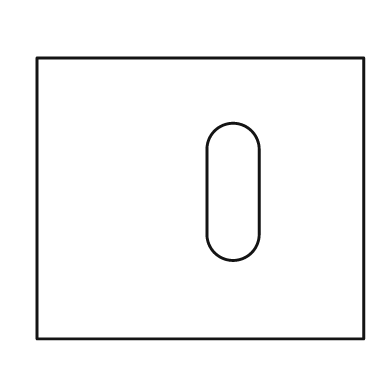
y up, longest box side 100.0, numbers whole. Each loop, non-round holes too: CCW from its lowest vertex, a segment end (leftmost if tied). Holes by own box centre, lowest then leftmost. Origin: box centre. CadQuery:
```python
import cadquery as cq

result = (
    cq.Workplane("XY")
    .moveTo(-50.0, -43.0)
    .lineTo(50.0, -43.0)
    .lineTo(50.0, 43.0)
    .lineTo(-50.0, 43.0)
    .close()
    .moveTo(2.0, -11.0)
    .threePointArc((10.0, -19.0), (18.0, -11.0))
    .lineTo(18.0, 15.0)
    .threePointArc((10.0, 23.0), (2.0, 15.0))
    .close()
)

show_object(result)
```